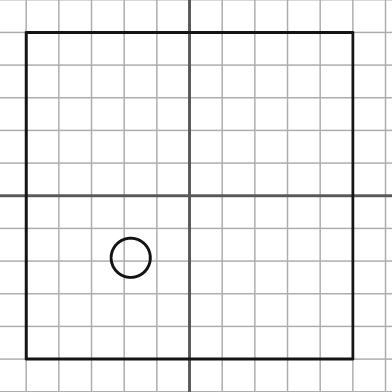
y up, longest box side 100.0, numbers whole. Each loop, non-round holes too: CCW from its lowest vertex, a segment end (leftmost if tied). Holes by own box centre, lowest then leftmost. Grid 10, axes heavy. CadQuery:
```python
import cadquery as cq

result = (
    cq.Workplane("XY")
    .moveTo(-50.0, -50.0)
    .lineTo(50.0, -50.0)
    .lineTo(50.0, 50.0)
    .lineTo(-50.0, 50.0)
    .close()
    .moveTo(-18.0, -19.0)
    .circle(6.0)
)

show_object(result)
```